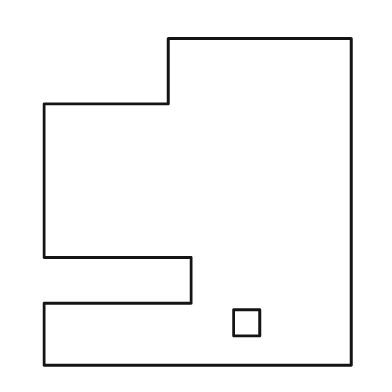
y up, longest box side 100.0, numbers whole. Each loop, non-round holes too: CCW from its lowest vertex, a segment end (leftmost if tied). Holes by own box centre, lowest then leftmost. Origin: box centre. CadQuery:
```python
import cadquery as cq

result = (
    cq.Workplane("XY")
    .moveTo(-47.0, -50.0)
    .lineTo(47.0, -50.0)
    .lineTo(47.0, 50.0)
    .lineTo(-9.0, 50.0)
    .lineTo(-9.0, 30.0)
    .lineTo(-47.0, 30.0)
    .lineTo(-47.0, -17.0)
    .lineTo(-2.0, -17.0)
    .lineTo(-2.0, -31.0)
    .lineTo(-47.0, -31.0)
    .close()
    .moveTo(11.0, -41.0)
    .lineTo(19.0, -41.0)
    .lineTo(19.0, -33.0)
    .lineTo(11.0, -33.0)
    .close()
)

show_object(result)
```